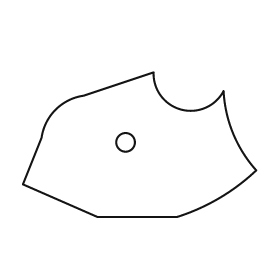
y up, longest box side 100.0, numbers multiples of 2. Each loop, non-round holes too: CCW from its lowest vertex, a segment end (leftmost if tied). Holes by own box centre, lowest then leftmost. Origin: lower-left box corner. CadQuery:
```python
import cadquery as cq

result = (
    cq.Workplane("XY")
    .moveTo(32.0, 0.0)
    .lineTo(66.0, 0.0)
    .threePointArc((84.0, 8.0), (100.0, 20.0))
    .threePointArc((90.0, 36.0), (86.0, 54.0))
    .threePointArc((68.0, 46.0), (56.0, 62.0))
    .lineTo(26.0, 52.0)
    .threePointArc((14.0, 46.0), (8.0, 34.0))
    .lineTo(0.0, 14.0)
    .close()
    .moveTo(44.0, 32.0)
    .circle(4.0)
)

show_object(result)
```